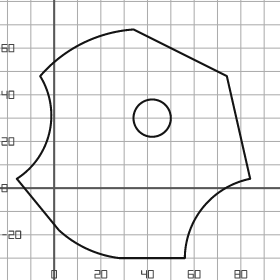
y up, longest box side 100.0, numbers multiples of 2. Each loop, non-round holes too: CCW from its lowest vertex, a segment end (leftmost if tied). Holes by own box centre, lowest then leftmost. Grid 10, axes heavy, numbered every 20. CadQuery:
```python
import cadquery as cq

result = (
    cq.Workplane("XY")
    .moveTo(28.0, -30.0)
    .lineTo(56.0, -30.0)
    .threePointArc((64.0, -8.0), (84.0, 4.0))
    .lineTo(74.0, 48.0)
    .lineTo(34.0, 68.0)
    .threePointArc((12.0, 62.0), (-6.0, 48.0))
    .threePointArc((-2.0, 24.0), (-16.0, 4.0))
    .lineTo(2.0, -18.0)
    .threePointArc((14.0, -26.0), (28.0, -30.0))
    .close()
    .moveTo(42.0, 30.0)
    .circle(8.0)
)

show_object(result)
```